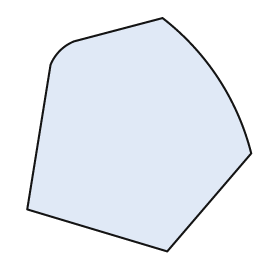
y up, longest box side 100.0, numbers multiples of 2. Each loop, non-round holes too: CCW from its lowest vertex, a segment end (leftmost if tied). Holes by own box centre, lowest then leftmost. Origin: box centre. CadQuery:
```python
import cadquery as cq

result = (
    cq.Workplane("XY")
    .moveTo(12.0, -50.0)
    .lineTo(48.0, -8.0)
    .threePointArc((34.0, 24.0), (10.0, 50.0))
    .lineTo(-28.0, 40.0)
    .threePointArc((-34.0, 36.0), (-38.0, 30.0))
    .lineTo(-48.0, -32.0)
    .close()
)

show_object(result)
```